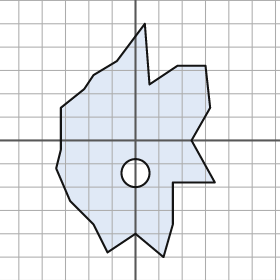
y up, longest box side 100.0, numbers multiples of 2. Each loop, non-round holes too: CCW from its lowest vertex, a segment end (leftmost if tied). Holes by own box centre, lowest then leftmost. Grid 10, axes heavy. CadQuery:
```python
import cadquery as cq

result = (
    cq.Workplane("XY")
    .moveTo(12.0, -50.0)
    .lineTo(16.0, -36.0)
    .lineTo(16.0, -18.0)
    .lineTo(34.0, -18.0)
    .lineTo(24.0, 0.0)
    .lineTo(32.0, 14.0)
    .lineTo(30.0, 32.0)
    .lineTo(18.0, 32.0)
    .lineTo(6.0, 24.0)
    .lineTo(4.0, 50.0)
    .lineTo(-8.0, 34.0)
    .lineTo(-18.0, 28.0)
    .lineTo(-22.0, 22.0)
    .lineTo(-32.0, 14.0)
    .lineTo(-32.0, -4.0)
    .lineTo(-34.0, -12.0)
    .lineTo(-28.0, -26.0)
    .lineTo(-18.0, -36.0)
    .lineTo(-12.0, -48.0)
    .lineTo(0.0, -40.0)
    .close()
    .moveTo(0.0, -14.0)
    .circle(6.0)
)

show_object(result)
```